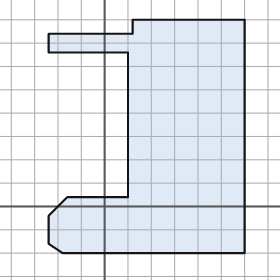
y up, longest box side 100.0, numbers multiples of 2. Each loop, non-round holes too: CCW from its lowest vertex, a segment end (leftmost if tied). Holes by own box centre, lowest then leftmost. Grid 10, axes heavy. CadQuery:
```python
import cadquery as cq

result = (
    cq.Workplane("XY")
    .moveTo(-18.0, -20.0)
    .lineTo(60.0, -20.0)
    .lineTo(60.0, 80.0)
    .lineTo(12.0, 80.0)
    .lineTo(12.0, 74.0)
    .lineTo(-24.0, 74.0)
    .lineTo(-24.0, 66.0)
    .lineTo(10.0, 66.0)
    .lineTo(10.0, 4.0)
    .lineTo(-16.0, 4.0)
    .lineTo(-24.0, -4.0)
    .lineTo(-24.0, -16.0)
    .close()
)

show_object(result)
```